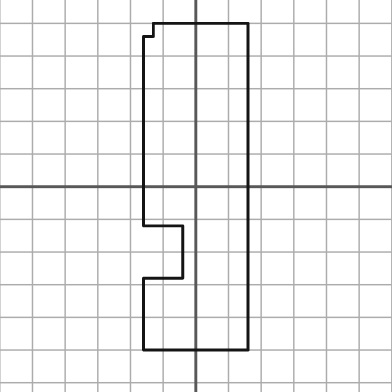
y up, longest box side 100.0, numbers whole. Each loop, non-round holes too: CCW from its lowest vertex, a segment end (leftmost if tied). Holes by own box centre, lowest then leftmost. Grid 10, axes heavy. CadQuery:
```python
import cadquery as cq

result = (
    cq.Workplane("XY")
    .moveTo(-16.0, -50.0)
    .lineTo(16.0, -50.0)
    .lineTo(16.0, 50.0)
    .lineTo(-13.0, 50.0)
    .lineTo(-13.0, 46.0)
    .lineTo(-16.0, 46.0)
    .lineTo(-16.0, -12.0)
    .lineTo(-4.0, -12.0)
    .lineTo(-4.0, -28.0)
    .lineTo(-16.0, -28.0)
    .close()
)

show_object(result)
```